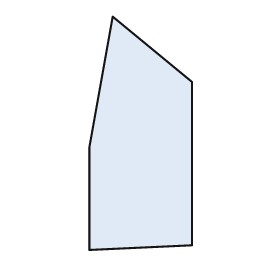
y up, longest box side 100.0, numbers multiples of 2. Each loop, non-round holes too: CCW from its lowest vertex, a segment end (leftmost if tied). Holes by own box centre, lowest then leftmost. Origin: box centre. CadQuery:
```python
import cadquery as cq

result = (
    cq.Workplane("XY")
    .moveTo(-22.0, -50.0)
    .lineTo(22.0, -48.0)
    .lineTo(22.0, 22.0)
    .lineTo(-12.0, 50.0)
    .lineTo(-22.0, -6.0)
    .close()
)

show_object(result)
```